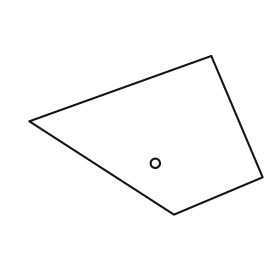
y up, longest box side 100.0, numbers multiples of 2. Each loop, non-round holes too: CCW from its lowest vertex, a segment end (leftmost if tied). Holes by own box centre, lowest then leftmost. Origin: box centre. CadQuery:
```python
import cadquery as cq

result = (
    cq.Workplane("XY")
    .moveTo(12.0, -34.0)
    .lineTo(50.0, -18.0)
    .lineTo(28.0, 34.0)
    .lineTo(-50.0, 6.0)
    .close()
    .moveTo(4.0, -12.0)
    .circle(2.0)
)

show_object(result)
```